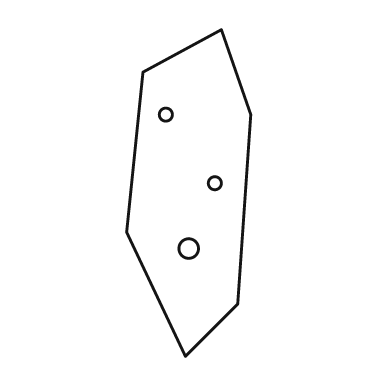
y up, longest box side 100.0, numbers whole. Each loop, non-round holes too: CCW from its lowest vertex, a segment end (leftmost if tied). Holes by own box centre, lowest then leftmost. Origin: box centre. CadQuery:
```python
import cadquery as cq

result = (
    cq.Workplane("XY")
    .moveTo(-1.0, -50.0)
    .lineTo(15.0, -34.0)
    .lineTo(19.0, 24.0)
    .lineTo(10.0, 50.0)
    .lineTo(-14.0, 37.0)
    .lineTo(-19.0, -12.0)
    .close()
    .moveTo(0.0, -17.0)
    .circle(3.0)
    .moveTo(8.0, 3.0)
    .circle(2.0)
    .moveTo(-7.0, 24.0)
    .circle(2.0)
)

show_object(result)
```